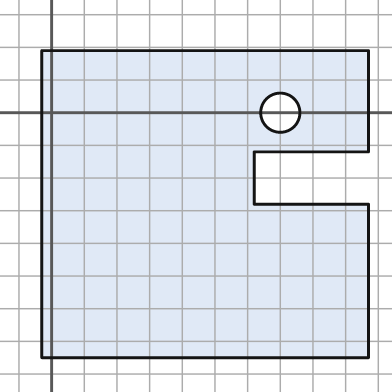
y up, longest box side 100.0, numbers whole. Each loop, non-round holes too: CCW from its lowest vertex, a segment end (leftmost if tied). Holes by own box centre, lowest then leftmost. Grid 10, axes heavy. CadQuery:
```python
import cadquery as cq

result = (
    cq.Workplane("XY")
    .moveTo(-3.0, -75.0)
    .lineTo(97.0, -75.0)
    .lineTo(97.0, -28.0)
    .lineTo(62.0, -28.0)
    .lineTo(62.0, -12.0)
    .lineTo(97.0, -12.0)
    .lineTo(97.0, 19.0)
    .lineTo(-3.0, 19.0)
    .close()
    .moveTo(70.0, 0.0)
    .circle(6.0)
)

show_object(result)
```